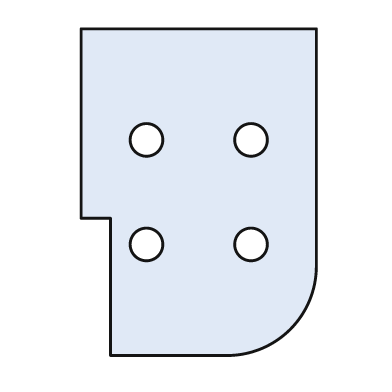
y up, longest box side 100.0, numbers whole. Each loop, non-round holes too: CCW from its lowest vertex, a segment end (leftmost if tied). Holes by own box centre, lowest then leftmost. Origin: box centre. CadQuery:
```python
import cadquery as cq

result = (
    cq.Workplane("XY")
    .moveTo(-27.0, -50.0)
    .lineTo(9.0, -50.0)
    .threePointArc((28.0, -42.0), (36.0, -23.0))
    .lineTo(36.0, 50.0)
    .lineTo(-36.0, 50.0)
    .lineTo(-36.0, -8.0)
    .lineTo(-27.0, -8.0)
    .close()
    .moveTo(-16.0, -16.0)
    .circle(5.0)
    .moveTo(16.0, -16.0)
    .circle(5.0)
    .moveTo(-16.0, 16.0)
    .circle(5.0)
    .moveTo(16.0, 16.0)
    .circle(5.0)
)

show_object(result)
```